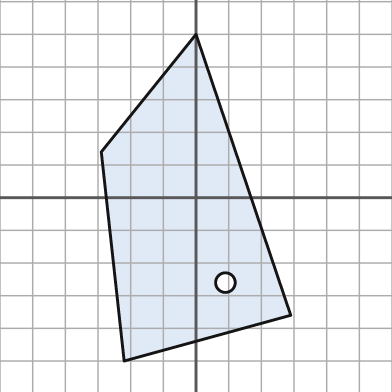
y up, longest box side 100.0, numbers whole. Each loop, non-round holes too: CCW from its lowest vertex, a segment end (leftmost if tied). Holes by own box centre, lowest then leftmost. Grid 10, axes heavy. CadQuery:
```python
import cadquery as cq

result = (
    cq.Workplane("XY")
    .moveTo(-22.0, -50.0)
    .lineTo(29.0, -36.0)
    .lineTo(0.0, 50.0)
    .lineTo(-29.0, 14.0)
    .close()
    .moveTo(9.0, -26.0)
    .circle(3.0)
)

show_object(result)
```